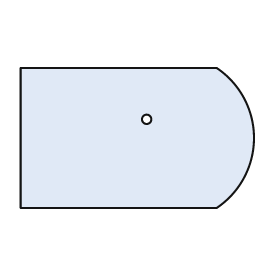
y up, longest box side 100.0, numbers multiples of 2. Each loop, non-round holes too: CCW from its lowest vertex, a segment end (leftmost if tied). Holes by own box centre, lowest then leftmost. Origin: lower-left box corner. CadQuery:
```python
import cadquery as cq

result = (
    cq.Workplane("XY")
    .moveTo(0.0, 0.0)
    .lineTo(84.0, 0.0)
    .threePointArc((100.0, 30.0), (84.0, 60.0))
    .lineTo(0.0, 60.0)
    .close()
    .moveTo(54.0, 38.0)
    .circle(2.0)
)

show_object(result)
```